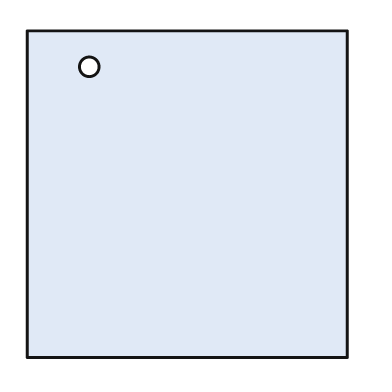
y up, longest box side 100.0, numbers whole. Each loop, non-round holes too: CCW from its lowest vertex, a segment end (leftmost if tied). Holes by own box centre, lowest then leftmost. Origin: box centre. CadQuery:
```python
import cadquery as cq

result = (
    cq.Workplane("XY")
    .moveTo(-49.0, -50.0)
    .lineTo(49.0, -50.0)
    .lineTo(49.0, 50.0)
    .lineTo(-49.0, 50.0)
    .close()
    .moveTo(-30.0, 39.0)
    .circle(3.0)
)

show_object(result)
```